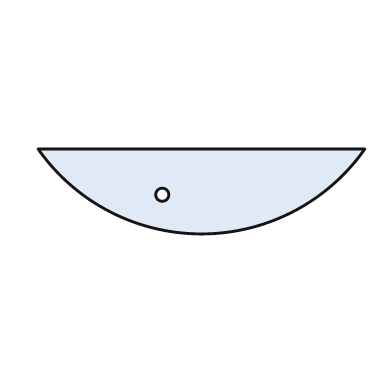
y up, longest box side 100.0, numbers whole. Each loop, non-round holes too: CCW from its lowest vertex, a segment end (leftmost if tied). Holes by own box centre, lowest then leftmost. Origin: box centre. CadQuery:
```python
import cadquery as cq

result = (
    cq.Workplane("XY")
    .moveTo(-50.0, 13.0)
    .threePointArc((0.0, -13.0), (50.0, 13.0))
    .close()
    .moveTo(-12.0, -1.0)
    .circle(2.0)
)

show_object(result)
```